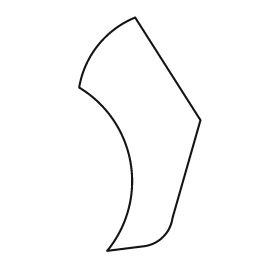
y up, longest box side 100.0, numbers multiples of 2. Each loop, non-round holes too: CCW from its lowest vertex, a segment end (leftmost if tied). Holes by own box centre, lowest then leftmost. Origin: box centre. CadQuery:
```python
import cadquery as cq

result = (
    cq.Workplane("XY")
    .moveTo(-14.0, -50.0)
    .lineTo(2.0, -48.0)
    .threePointArc((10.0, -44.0), (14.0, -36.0))
    .lineTo(26.0, 6.0)
    .lineTo(-2.0, 50.0)
    .threePointArc((-18.0, 38.0), (-26.0, 20.0))
    .threePointArc((-4.0, -12.0), (-14.0, -50.0))
    .close()
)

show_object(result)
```